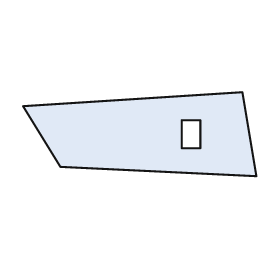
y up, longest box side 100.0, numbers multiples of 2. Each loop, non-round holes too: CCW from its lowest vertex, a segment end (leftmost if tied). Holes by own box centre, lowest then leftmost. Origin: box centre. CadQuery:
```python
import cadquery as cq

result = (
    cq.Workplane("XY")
    .moveTo(50.0, -18.0)
    .lineTo(44.0, 18.0)
    .lineTo(-50.0, 12.0)
    .lineTo(-34.0, -14.0)
    .close()
    .moveTo(18.0, -6.0)
    .lineTo(26.0, -6.0)
    .lineTo(26.0, 6.0)
    .lineTo(18.0, 6.0)
    .close()
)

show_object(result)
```